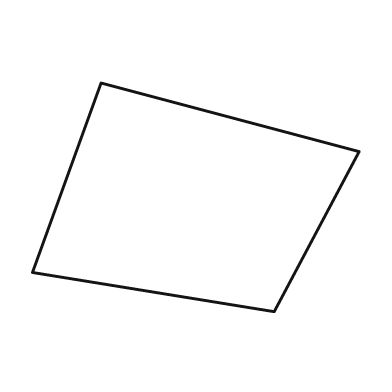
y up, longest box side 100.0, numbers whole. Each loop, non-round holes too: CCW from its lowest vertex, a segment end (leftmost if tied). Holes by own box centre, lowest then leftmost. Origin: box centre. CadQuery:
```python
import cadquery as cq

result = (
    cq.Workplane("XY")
    .moveTo(24.0, -35.0)
    .lineTo(50.0, 14.0)
    .lineTo(-29.0, 35.0)
    .lineTo(-50.0, -23.0)
    .close()
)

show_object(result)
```